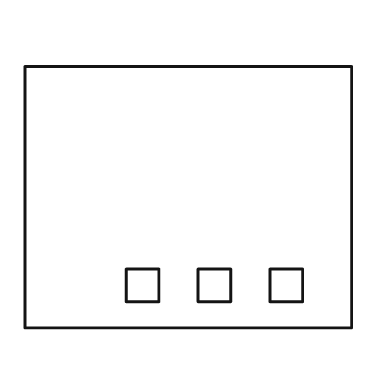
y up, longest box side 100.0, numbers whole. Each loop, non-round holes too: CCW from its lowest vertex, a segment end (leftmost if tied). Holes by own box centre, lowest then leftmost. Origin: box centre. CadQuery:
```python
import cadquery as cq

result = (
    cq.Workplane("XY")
    .moveTo(-50.0, -40.0)
    .lineTo(50.0, -40.0)
    .lineTo(50.0, 40.0)
    .lineTo(-50.0, 40.0)
    .close()
    .moveTo(-19.0, -32.0)
    .lineTo(-9.0, -32.0)
    .lineTo(-9.0, -22.0)
    .lineTo(-19.0, -22.0)
    .close()
    .moveTo(3.0, -32.0)
    .lineTo(13.0, -32.0)
    .lineTo(13.0, -22.0)
    .lineTo(3.0, -22.0)
    .close()
    .moveTo(25.0, -32.0)
    .lineTo(35.0, -32.0)
    .lineTo(35.0, -22.0)
    .lineTo(25.0, -22.0)
    .close()
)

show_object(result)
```